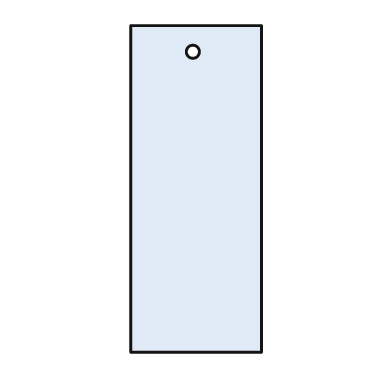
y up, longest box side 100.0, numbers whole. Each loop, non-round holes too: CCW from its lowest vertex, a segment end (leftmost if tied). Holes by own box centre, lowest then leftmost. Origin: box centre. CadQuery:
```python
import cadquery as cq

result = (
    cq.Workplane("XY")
    .moveTo(-20.0, -50.0)
    .lineTo(20.0, -50.0)
    .lineTo(20.0, 50.0)
    .lineTo(-20.0, 50.0)
    .close()
    .moveTo(-1.0, 42.0)
    .circle(2.0)
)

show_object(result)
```